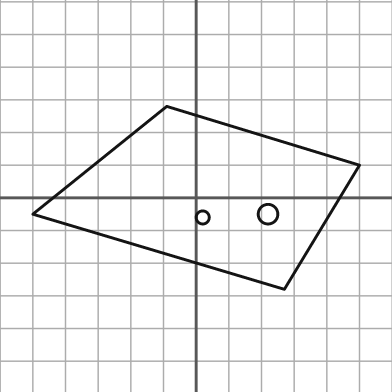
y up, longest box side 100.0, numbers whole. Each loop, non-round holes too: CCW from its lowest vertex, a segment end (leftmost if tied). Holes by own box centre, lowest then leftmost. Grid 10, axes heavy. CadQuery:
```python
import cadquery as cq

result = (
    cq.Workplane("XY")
    .moveTo(27.0, -28.0)
    .lineTo(50.0, 10.0)
    .lineTo(-9.0, 28.0)
    .lineTo(-50.0, -5.0)
    .close()
    .moveTo(2.0, -6.0)
    .circle(2.0)
    .moveTo(22.0, -5.0)
    .circle(3.0)
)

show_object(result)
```